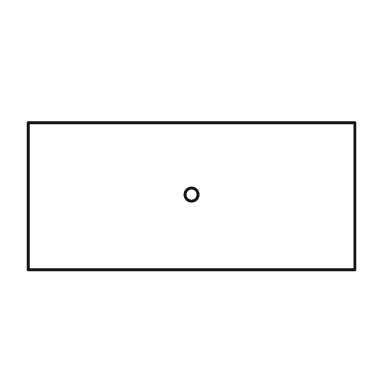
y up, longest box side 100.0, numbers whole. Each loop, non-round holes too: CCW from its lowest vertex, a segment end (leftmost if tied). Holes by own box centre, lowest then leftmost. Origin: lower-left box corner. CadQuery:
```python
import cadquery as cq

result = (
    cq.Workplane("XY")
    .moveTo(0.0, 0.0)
    .lineTo(100.0, 0.0)
    .lineTo(100.0, 45.0)
    .lineTo(0.0, 45.0)
    .close()
    .moveTo(50.0, 23.0)
    .circle(2.0)
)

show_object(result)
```